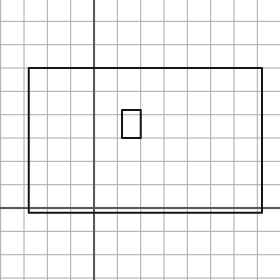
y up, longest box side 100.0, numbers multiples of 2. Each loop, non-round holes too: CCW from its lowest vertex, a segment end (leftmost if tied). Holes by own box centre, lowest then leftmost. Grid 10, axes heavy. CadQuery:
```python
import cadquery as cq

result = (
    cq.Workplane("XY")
    .moveTo(-28.0, -2.0)
    .lineTo(72.0, -2.0)
    .lineTo(72.0, 60.0)
    .lineTo(-28.0, 60.0)
    .close()
    .moveTo(12.0, 30.0)
    .lineTo(20.0, 30.0)
    .lineTo(20.0, 42.0)
    .lineTo(12.0, 42.0)
    .close()
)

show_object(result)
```